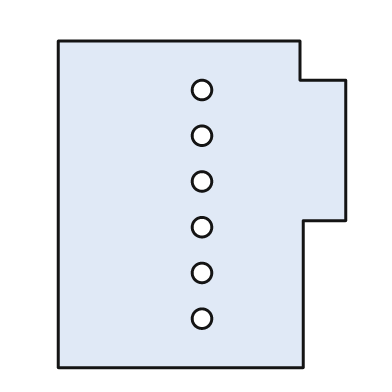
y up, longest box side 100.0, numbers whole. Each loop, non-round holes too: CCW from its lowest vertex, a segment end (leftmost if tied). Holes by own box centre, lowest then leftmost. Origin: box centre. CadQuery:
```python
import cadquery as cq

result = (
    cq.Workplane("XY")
    .moveTo(-44.0, -50.0)
    .lineTo(31.0, -50.0)
    .lineTo(31.0, -5.0)
    .lineTo(44.0, -5.0)
    .lineTo(44.0, 38.0)
    .lineTo(30.0, 38.0)
    .lineTo(30.0, 50.0)
    .lineTo(-44.0, 50.0)
    .close()
    .moveTo(0.0, -35.0)
    .circle(3.0)
    .moveTo(0.0, -21.0)
    .circle(3.0)
    .moveTo(0.0, -7.0)
    .circle(3.0)
    .moveTo(0.0, 7.0)
    .circle(3.0)
    .moveTo(0.0, 21.0)
    .circle(3.0)
    .moveTo(0.0, 35.0)
    .circle(3.0)
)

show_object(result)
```